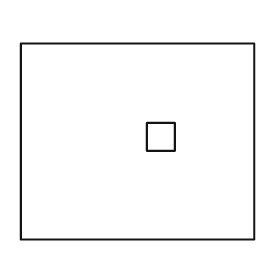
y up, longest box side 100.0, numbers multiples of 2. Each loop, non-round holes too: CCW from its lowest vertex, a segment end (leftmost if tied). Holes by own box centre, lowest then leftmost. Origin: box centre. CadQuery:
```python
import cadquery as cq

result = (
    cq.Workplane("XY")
    .moveTo(-50.0, -42.0)
    .lineTo(50.0, -42.0)
    .lineTo(50.0, 42.0)
    .lineTo(-50.0, 42.0)
    .close()
    .moveTo(4.0, -4.0)
    .lineTo(16.0, -4.0)
    .lineTo(16.0, 8.0)
    .lineTo(4.0, 8.0)
    .close()
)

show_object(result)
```